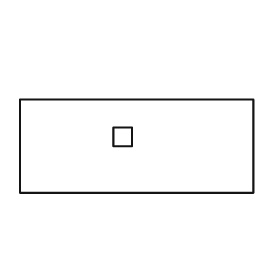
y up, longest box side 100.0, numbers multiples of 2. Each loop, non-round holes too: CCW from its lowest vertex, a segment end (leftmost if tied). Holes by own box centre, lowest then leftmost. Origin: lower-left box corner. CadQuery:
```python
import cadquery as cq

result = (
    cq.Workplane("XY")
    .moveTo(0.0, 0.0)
    .lineTo(100.0, 0.0)
    .lineTo(100.0, 40.0)
    .lineTo(0.0, 40.0)
    .close()
    .moveTo(40.0, 20.0)
    .lineTo(48.0, 20.0)
    .lineTo(48.0, 28.0)
    .lineTo(40.0, 28.0)
    .close()
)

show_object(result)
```